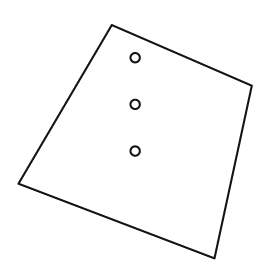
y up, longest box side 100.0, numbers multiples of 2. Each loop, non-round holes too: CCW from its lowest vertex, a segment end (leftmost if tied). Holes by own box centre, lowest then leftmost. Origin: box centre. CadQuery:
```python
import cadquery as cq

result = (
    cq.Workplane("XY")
    .moveTo(34.0, -50.0)
    .lineTo(50.0, 24.0)
    .lineTo(-10.0, 50.0)
    .lineTo(-50.0, -18.0)
    .close()
    .moveTo(0.0, -4.0)
    .circle(2.0)
    .moveTo(0.0, 16.0)
    .circle(2.0)
    .moveTo(0.0, 36.0)
    .circle(2.0)
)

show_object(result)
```